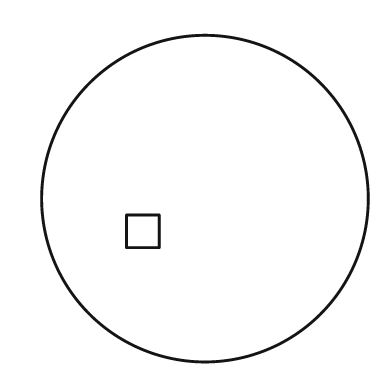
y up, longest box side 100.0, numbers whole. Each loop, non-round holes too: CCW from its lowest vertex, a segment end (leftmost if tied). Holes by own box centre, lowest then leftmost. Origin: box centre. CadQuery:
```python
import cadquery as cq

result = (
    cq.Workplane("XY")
    .moveTo(0.0, 0.0)
    .circle(50.0)
    .moveTo(-24.0, -15.0)
    .lineTo(-14.0, -15.0)
    .lineTo(-14.0, -5.0)
    .lineTo(-24.0, -5.0)
    .close()
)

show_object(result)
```